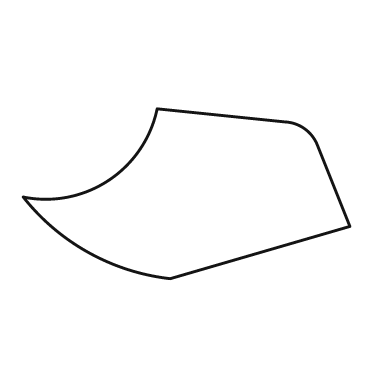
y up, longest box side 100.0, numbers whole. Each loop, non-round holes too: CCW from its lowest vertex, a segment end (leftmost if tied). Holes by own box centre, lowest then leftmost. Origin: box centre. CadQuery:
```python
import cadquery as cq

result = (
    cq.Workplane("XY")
    .moveTo(-5.0, -26.0)
    .lineTo(50.0, -10.0)
    .lineTo(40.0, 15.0)
    .threePointArc((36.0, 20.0), (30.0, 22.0))
    .lineTo(-9.0, 26.0)
    .threePointArc((-24.0, 4.0), (-50.0, -1.0))
    .threePointArc((-30.0, -18.0), (-5.0, -26.0))
    .close()
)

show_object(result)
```